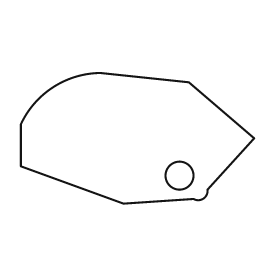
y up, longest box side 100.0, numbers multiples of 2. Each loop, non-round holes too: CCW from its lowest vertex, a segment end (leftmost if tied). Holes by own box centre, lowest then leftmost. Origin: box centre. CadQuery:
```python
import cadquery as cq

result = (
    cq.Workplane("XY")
    .moveTo(-6.0, -28.0)
    .lineTo(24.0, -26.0)
    .threePointArc((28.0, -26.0), (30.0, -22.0))
    .lineTo(50.0, 0.0)
    .lineTo(22.0, 24.0)
    .lineTo(-16.0, 28.0)
    .threePointArc((-36.0, 22.0), (-50.0, 6.0))
    .lineTo(-50.0, -12.0)
    .close()
    .moveTo(18.0, -16.0)
    .circle(6.0)
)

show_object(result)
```